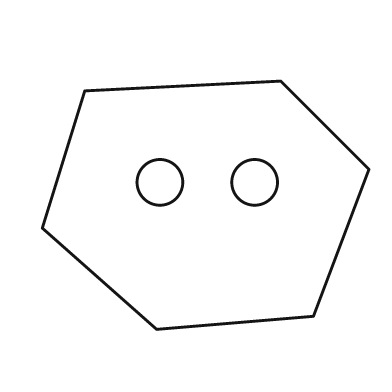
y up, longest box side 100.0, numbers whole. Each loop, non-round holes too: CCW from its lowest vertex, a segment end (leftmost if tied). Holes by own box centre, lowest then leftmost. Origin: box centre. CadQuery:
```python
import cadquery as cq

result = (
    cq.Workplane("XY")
    .moveTo(-15.0, -38.0)
    .lineTo(33.0, -34.0)
    .lineTo(50.0, 11.0)
    .lineTo(23.0, 38.0)
    .lineTo(-37.0, 35.0)
    .lineTo(-50.0, -7.0)
    .close()
    .moveTo(-14.0, 7.0)
    .circle(7.0)
    .moveTo(15.0, 7.0)
    .circle(7.0)
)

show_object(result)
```